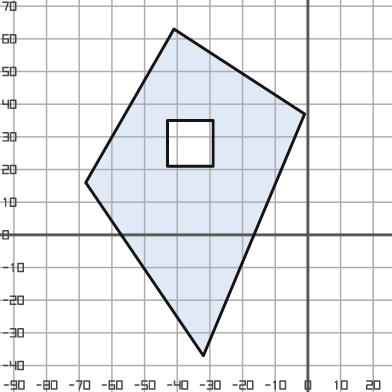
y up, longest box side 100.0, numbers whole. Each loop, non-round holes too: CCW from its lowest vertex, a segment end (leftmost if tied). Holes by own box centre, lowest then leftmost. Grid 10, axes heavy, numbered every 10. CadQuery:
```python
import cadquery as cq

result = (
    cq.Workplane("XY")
    .moveTo(-32.0, -37.0)
    .lineTo(-1.0, 37.0)
    .lineTo(-41.0, 63.0)
    .lineTo(-68.0, 16.0)
    .close()
    .moveTo(-43.0, 21.0)
    .lineTo(-29.0, 21.0)
    .lineTo(-29.0, 35.0)
    .lineTo(-43.0, 35.0)
    .close()
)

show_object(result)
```